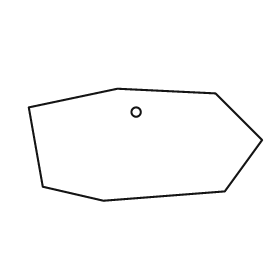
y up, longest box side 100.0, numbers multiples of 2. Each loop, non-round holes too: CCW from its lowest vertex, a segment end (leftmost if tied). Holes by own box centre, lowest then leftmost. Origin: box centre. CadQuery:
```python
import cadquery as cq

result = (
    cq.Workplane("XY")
    .moveTo(-18.0, -24.0)
    .lineTo(34.0, -20.0)
    .lineTo(50.0, 2.0)
    .lineTo(30.0, 22.0)
    .lineTo(-12.0, 24.0)
    .lineTo(-50.0, 16.0)
    .lineTo(-44.0, -18.0)
    .close()
    .moveTo(-4.0, 14.0)
    .circle(2.0)
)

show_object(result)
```